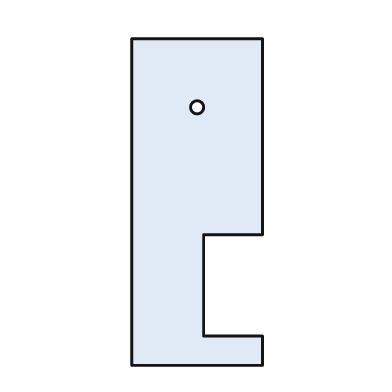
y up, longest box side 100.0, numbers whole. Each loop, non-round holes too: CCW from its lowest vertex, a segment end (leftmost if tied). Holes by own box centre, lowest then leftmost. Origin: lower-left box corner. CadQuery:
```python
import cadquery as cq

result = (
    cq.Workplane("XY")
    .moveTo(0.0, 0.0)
    .lineTo(40.0, 0.0)
    .lineTo(40.0, 9.0)
    .lineTo(22.0, 9.0)
    .lineTo(22.0, 40.0)
    .lineTo(40.0, 40.0)
    .lineTo(40.0, 100.0)
    .lineTo(0.0, 100.0)
    .close()
    .moveTo(20.0, 79.0)
    .circle(2.0)
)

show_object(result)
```